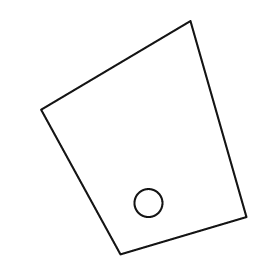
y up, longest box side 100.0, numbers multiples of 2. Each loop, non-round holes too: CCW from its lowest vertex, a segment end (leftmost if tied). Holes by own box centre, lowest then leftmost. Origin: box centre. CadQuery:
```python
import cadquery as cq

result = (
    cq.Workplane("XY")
    .moveTo(-10.0, -50.0)
    .lineTo(44.0, -34.0)
    .lineTo(20.0, 50.0)
    .lineTo(-44.0, 12.0)
    .close()
    .moveTo(2.0, -28.0)
    .circle(6.0)
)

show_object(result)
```